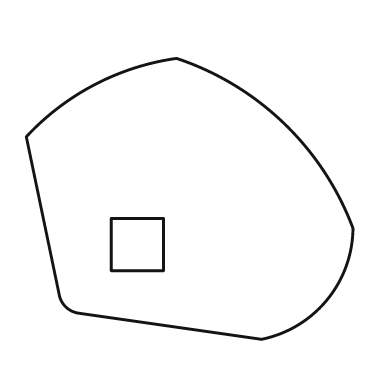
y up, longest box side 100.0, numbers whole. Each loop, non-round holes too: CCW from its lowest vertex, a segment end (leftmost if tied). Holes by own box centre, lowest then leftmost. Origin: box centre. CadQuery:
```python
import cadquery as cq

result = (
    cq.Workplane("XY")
    .moveTo(22.0, -43.0)
    .threePointArc((42.0, -31.0), (50.0, -9.0))
    .threePointArc((29.0, 23.0), (-4.0, 43.0))
    .threePointArc((-29.0, 35.0), (-50.0, 19.0))
    .lineTo(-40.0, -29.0)
    .threePointArc((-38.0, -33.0), (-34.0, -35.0))
    .close()
    .moveTo(-24.0, -22.0)
    .lineTo(-8.0, -22.0)
    .lineTo(-8.0, -6.0)
    .lineTo(-24.0, -6.0)
    .close()
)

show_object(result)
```